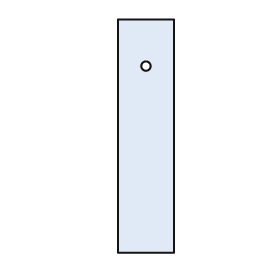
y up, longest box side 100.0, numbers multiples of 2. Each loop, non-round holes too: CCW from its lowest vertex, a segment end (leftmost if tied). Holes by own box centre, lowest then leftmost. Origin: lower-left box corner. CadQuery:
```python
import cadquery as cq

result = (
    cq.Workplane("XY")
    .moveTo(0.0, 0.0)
    .lineTo(24.0, 0.0)
    .lineTo(24.0, 100.0)
    .lineTo(0.0, 100.0)
    .close()
    .moveTo(12.0, 80.0)
    .circle(2.0)
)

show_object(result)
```